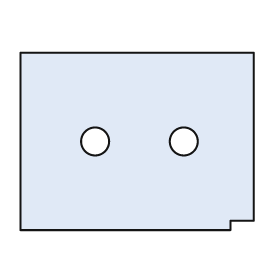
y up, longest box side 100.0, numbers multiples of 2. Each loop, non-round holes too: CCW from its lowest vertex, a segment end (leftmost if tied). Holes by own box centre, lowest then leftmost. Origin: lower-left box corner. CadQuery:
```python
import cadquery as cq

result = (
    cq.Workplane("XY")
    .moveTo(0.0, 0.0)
    .lineTo(90.0, 0.0)
    .lineTo(90.0, 4.0)
    .lineTo(100.0, 4.0)
    .lineTo(100.0, 76.0)
    .lineTo(0.0, 76.0)
    .close()
    .moveTo(32.0, 38.0)
    .circle(6.0)
    .moveTo(70.0, 38.0)
    .circle(6.0)
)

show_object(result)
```